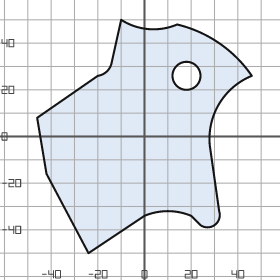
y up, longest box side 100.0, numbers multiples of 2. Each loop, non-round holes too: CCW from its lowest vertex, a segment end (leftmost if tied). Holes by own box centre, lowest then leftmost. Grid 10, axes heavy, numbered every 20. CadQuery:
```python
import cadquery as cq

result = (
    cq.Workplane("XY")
    .moveTo(-24.0, -50.0)
    .lineTo(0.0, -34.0)
    .threePointArc((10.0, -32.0), (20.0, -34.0))
    .lineTo(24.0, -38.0)
    .threePointArc((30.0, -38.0), (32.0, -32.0))
    .lineTo(28.0, -4.0)
    .threePointArc((32.0, 14.0), (46.0, 26.0))
    .threePointArc((32.0, 40.0), (14.0, 48.0))
    .threePointArc((2.0, 46.0), (-10.0, 50.0))
    .lineTo(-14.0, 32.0)
    .threePointArc((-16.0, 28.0), (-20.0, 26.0))
    .lineTo(-46.0, 8.0)
    .lineTo(-42.0, -16.0)
    .close()
    .moveTo(18.0, 26.0)
    .circle(6.0)
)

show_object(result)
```